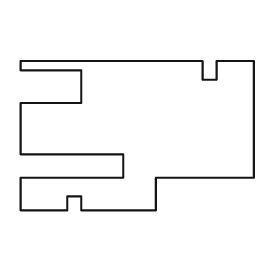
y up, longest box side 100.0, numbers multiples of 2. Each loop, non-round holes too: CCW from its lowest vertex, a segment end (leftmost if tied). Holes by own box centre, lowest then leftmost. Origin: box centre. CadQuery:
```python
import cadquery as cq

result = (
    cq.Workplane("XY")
    .moveTo(-50.0, -32.0)
    .lineTo(-30.0, -32.0)
    .lineTo(-30.0, -26.0)
    .lineTo(-24.0, -26.0)
    .lineTo(-24.0, -32.0)
    .lineTo(8.0, -32.0)
    .lineTo(8.0, -18.0)
    .lineTo(50.0, -18.0)
    .lineTo(50.0, 32.0)
    .lineTo(34.0, 32.0)
    .lineTo(34.0, 24.0)
    .lineTo(28.0, 24.0)
    .lineTo(28.0, 32.0)
    .lineTo(-50.0, 32.0)
    .lineTo(-50.0, 28.0)
    .lineTo(-24.0, 28.0)
    .lineTo(-24.0, 14.0)
    .lineTo(-50.0, 14.0)
    .lineTo(-50.0, -8.0)
    .lineTo(-6.0, -8.0)
    .lineTo(-6.0, -18.0)
    .lineTo(-50.0, -18.0)
    .close()
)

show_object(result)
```